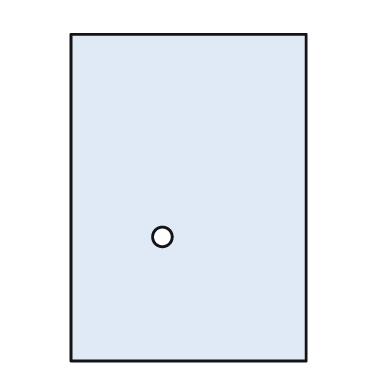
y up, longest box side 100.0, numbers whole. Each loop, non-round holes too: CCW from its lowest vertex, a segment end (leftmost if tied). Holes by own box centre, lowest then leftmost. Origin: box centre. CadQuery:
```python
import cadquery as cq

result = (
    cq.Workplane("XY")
    .moveTo(-36.0, -50.0)
    .lineTo(36.0, -50.0)
    .lineTo(36.0, 50.0)
    .lineTo(-36.0, 50.0)
    .close()
    .moveTo(-8.0, -12.0)
    .circle(3.0)
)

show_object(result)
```